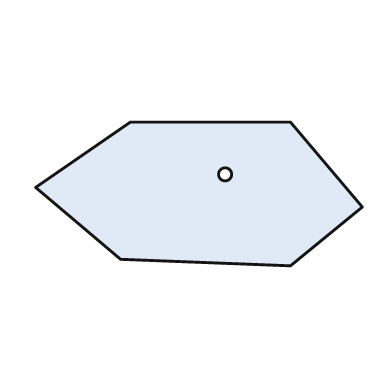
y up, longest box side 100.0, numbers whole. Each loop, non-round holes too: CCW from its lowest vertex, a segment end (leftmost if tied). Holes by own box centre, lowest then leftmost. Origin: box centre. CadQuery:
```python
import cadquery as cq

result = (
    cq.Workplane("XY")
    .moveTo(28.0, -22.0)
    .lineTo(50.0, -4.0)
    .lineTo(28.0, 22.0)
    .lineTo(-21.0, 22.0)
    .lineTo(-50.0, 2.0)
    .lineTo(-24.0, -20.0)
    .close()
    .moveTo(8.0, 6.0)
    .circle(2.0)
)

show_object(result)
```